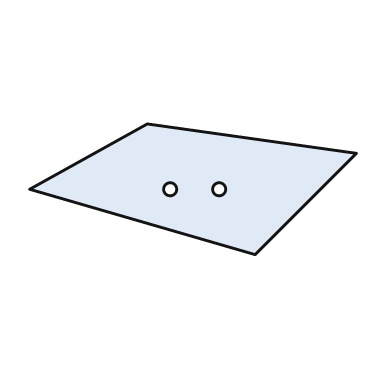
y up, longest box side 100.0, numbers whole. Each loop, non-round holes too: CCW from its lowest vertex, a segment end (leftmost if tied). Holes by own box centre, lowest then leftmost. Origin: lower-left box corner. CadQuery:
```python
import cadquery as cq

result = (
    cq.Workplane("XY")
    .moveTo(69.0, 0.0)
    .lineTo(100.0, 31.0)
    .lineTo(36.0, 40.0)
    .lineTo(0.0, 20.0)
    .close()
    .moveTo(43.0, 20.0)
    .circle(2.0)
    .moveTo(58.0, 20.0)
    .circle(2.0)
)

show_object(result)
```